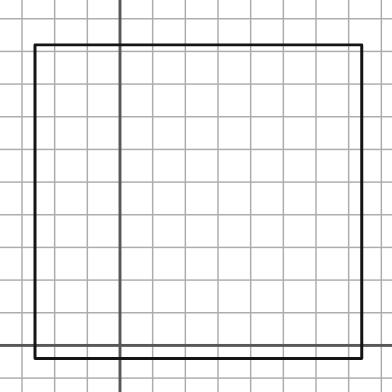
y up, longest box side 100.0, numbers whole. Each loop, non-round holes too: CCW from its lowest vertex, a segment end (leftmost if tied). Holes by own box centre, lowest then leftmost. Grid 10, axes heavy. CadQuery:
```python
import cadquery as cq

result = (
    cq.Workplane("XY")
    .moveTo(-26.0, -4.0)
    .lineTo(74.0, -4.0)
    .lineTo(74.0, 92.0)
    .lineTo(-26.0, 92.0)
    .close()
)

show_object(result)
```